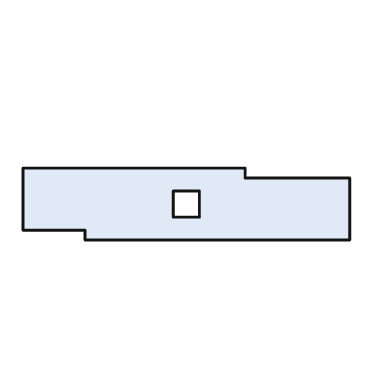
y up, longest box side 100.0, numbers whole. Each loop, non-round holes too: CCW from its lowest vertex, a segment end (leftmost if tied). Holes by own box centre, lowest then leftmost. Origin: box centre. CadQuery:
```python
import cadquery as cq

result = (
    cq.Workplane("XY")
    .moveTo(-31.0, -11.0)
    .lineTo(50.0, -11.0)
    .lineTo(50.0, 8.0)
    .lineTo(18.0, 8.0)
    .lineTo(18.0, 11.0)
    .lineTo(-50.0, 11.0)
    .lineTo(-50.0, -8.0)
    .lineTo(-31.0, -8.0)
    .close()
    .moveTo(-4.0, -4.0)
    .lineTo(4.0, -4.0)
    .lineTo(4.0, 4.0)
    .lineTo(-4.0, 4.0)
    .close()
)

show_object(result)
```